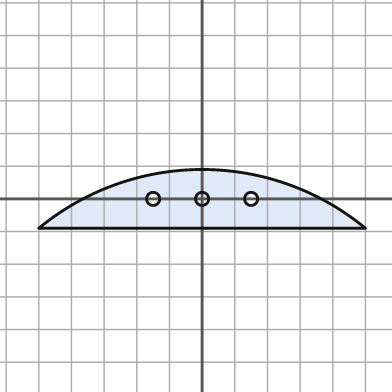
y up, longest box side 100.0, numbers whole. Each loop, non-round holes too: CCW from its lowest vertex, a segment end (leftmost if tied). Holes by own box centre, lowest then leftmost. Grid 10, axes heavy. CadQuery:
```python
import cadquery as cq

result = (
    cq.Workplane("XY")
    .moveTo(-50.0, -9.0)
    .lineTo(50.0, -9.0)
    .threePointArc((0.0, 9.0), (-50.0, -9.0))
    .close()
    .moveTo(-15.0, 0.0)
    .circle(2.0)
    .moveTo(0.0, 0.0)
    .circle(2.0)
    .moveTo(15.0, 0.0)
    .circle(2.0)
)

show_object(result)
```